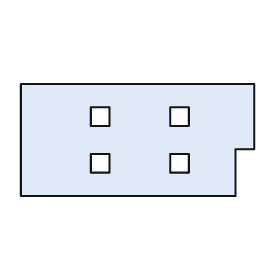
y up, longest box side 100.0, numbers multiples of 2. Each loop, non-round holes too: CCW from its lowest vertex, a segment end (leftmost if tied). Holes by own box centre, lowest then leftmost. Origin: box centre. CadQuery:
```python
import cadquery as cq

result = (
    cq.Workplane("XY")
    .moveTo(-50.0, -24.0)
    .lineTo(42.0, -24.0)
    .lineTo(42.0, -4.0)
    .lineTo(50.0, -4.0)
    .lineTo(50.0, 24.0)
    .lineTo(-50.0, 24.0)
    .close()
    .moveTo(-20.0, -14.0)
    .lineTo(-12.0, -14.0)
    .lineTo(-12.0, -6.0)
    .lineTo(-20.0, -6.0)
    .close()
    .moveTo(14.0, -14.0)
    .lineTo(22.0, -14.0)
    .lineTo(22.0, -6.0)
    .lineTo(14.0, -6.0)
    .close()
    .moveTo(-20.0, 6.0)
    .lineTo(-12.0, 6.0)
    .lineTo(-12.0, 14.0)
    .lineTo(-20.0, 14.0)
    .close()
    .moveTo(14.0, 6.0)
    .lineTo(22.0, 6.0)
    .lineTo(22.0, 14.0)
    .lineTo(14.0, 14.0)
    .close()
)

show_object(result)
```